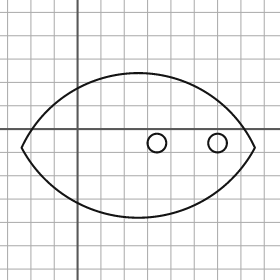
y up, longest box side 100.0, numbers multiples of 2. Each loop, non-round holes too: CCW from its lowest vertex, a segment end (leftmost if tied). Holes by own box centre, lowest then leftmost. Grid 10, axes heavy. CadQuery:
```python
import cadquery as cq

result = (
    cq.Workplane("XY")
    .moveTo(-24.0, -8.0)
    .threePointArc((26.0, -38.0), (76.0, -8.0))
    .threePointArc((26.0, 24.0), (-24.0, -8.0))
    .close()
    .moveTo(34.0, -6.0)
    .circle(4.0)
    .moveTo(60.0, -6.0)
    .circle(4.0)
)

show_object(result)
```